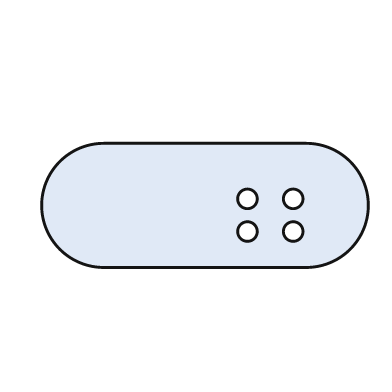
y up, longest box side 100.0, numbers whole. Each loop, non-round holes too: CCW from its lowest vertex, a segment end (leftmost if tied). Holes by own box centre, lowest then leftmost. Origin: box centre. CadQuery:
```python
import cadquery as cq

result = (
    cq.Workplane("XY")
    .moveTo(-31.0, -19.0)
    .lineTo(31.0, -19.0)
    .threePointArc((50.0, 0.0), (31.0, 19.0))
    .lineTo(-31.0, 19.0)
    .threePointArc((-50.0, 0.0), (-31.0, -19.0))
    .close()
    .moveTo(13.0, -8.0)
    .circle(3.0)
    .moveTo(27.0, -8.0)
    .circle(3.0)
    .moveTo(13.0, 2.0)
    .circle(3.0)
    .moveTo(27.0, 2.0)
    .circle(3.0)
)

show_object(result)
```